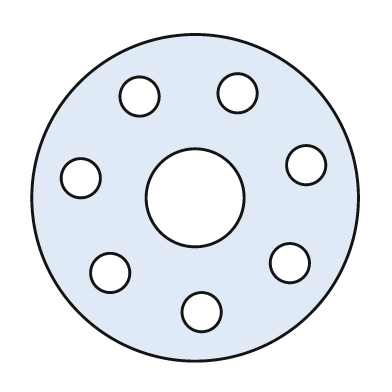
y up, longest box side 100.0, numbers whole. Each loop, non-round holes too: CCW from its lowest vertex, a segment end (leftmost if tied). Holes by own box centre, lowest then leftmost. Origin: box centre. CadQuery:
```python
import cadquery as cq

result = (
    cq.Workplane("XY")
    .moveTo(0.0, 0.0)
    .circle(50.0)
    .moveTo(2.0, -35.0)
    .circle(6.0)
    .moveTo(-26.0, -23.0)
    .circle(6.0)
    .moveTo(29.0, -20.0)
    .circle(6.0)
    .moveTo(0.0, 0.0)
    .circle(15.0)
    .moveTo(-35.0, 6.0)
    .circle(6.0)
    .moveTo(34.0, 10.0)
    .circle(6.0)
    .moveTo(-17.0, 31.0)
    .circle(6.0)
    .moveTo(13.0, 32.0)
    .circle(6.0)
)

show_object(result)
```